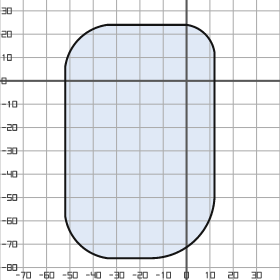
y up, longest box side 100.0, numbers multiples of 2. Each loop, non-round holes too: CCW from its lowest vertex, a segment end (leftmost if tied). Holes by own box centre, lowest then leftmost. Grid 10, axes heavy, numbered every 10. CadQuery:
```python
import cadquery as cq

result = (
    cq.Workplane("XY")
    .moveTo(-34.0, -76.0)
    .lineTo(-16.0, -76.0)
    .threePointArc((4.0, -68.0), (12.0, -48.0))
    .lineTo(12.0, 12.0)
    .threePointArc((8.0, 20.0), (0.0, 24.0))
    .lineTo(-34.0, 24.0)
    .threePointArc((-46.0, 18.0), (-52.0, 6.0))
    .lineTo(-52.0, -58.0)
    .threePointArc((-46.0, -70.0), (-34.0, -76.0))
    .close()
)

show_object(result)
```